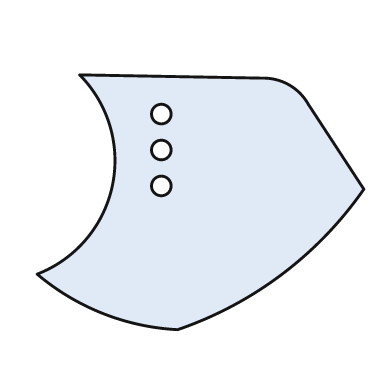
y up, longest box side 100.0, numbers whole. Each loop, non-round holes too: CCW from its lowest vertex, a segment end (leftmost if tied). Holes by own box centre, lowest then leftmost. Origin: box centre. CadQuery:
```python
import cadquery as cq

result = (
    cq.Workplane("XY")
    .moveTo(-7.0, -39.0)
    .threePointArc((25.0, -22.0), (50.0, 4.0))
    .lineTo(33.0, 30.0)
    .threePointArc((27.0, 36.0), (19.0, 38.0))
    .lineTo(-37.0, 39.0)
    .threePointArc((-27.0, 5.0), (-50.0, -22.0))
    .threePointArc((-30.0, -34.0), (-7.0, -39.0))
    .close()
    .moveTo(-12.0, 5.0)
    .circle(3.0)
    .moveTo(-12.0, 16.0)
    .circle(3.0)
    .moveTo(-12.0, 27.0)
    .circle(3.0)
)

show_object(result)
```